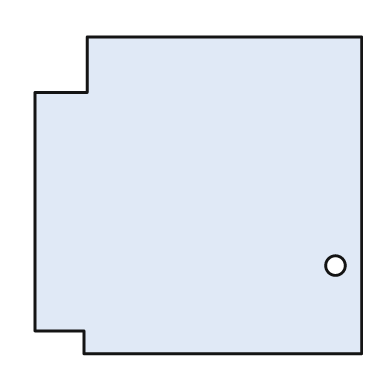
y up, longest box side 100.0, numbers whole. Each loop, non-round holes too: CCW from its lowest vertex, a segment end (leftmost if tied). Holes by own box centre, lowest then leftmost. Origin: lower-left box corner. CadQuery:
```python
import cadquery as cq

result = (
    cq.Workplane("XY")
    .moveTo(15.0, 0.0)
    .lineTo(100.0, 0.0)
    .lineTo(100.0, 97.0)
    .lineTo(16.0, 97.0)
    .lineTo(16.0, 80.0)
    .lineTo(0.0, 80.0)
    .lineTo(0.0, 7.0)
    .lineTo(15.0, 7.0)
    .close()
    .moveTo(92.0, 27.0)
    .circle(3.0)
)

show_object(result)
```